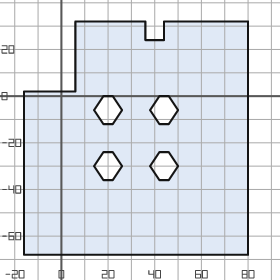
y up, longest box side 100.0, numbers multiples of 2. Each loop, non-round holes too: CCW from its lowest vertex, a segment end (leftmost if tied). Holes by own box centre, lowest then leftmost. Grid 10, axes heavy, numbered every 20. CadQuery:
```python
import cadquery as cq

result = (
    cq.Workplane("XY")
    .moveTo(-16.0, -68.0)
    .lineTo(80.0, -68.0)
    .lineTo(80.0, 32.0)
    .lineTo(44.0, 32.0)
    .lineTo(44.0, 24.0)
    .lineTo(36.0, 24.0)
    .lineTo(36.0, 32.0)
    .lineTo(6.0, 32.0)
    .lineTo(6.0, 2.0)
    .lineTo(-16.0, 2.0)
    .close()
    .moveTo(18.0, -36.0)
    .lineTo(22.0, -36.0)
    .lineTo(26.0, -30.0)
    .lineTo(22.0, -24.0)
    .lineTo(18.0, -24.0)
    .lineTo(14.0, -30.0)
    .close()
    .moveTo(42.0, -36.0)
    .lineTo(46.0, -36.0)
    .lineTo(50.0, -30.0)
    .lineTo(46.0, -24.0)
    .lineTo(42.0, -24.0)
    .lineTo(38.0, -30.0)
    .close()
    .moveTo(18.0, -12.0)
    .lineTo(22.0, -12.0)
    .lineTo(26.0, -6.0)
    .lineTo(22.0, 0.0)
    .lineTo(18.0, 0.0)
    .lineTo(14.0, -6.0)
    .close()
    .moveTo(42.0, -12.0)
    .lineTo(46.0, -12.0)
    .lineTo(50.0, -6.0)
    .lineTo(46.0, 0.0)
    .lineTo(42.0, 0.0)
    .lineTo(38.0, -6.0)
    .close()
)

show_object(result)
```